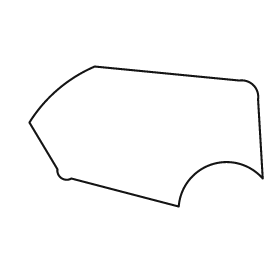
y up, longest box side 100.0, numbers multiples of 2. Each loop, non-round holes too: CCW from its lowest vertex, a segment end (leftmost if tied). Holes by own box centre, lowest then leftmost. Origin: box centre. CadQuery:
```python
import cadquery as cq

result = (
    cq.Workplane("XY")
    .moveTo(14.0, -30.0)
    .threePointArc((28.0, -12.0), (50.0, -18.0))
    .lineTo(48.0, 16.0)
    .threePointArc((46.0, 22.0), (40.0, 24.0))
    .lineTo(-22.0, 30.0)
    .threePointArc((-38.0, 20.0), (-50.0, 6.0))
    .lineTo(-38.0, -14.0)
    .threePointArc((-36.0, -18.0), (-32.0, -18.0))
    .close()
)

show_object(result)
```